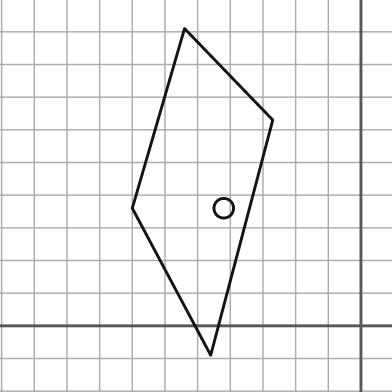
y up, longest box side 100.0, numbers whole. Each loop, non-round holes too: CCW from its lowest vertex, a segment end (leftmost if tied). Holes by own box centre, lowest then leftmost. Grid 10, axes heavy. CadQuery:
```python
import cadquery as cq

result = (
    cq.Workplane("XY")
    .moveTo(-46.0, -9.0)
    .lineTo(-27.0, 63.0)
    .lineTo(-54.0, 91.0)
    .lineTo(-70.0, 36.0)
    .close()
    .moveTo(-42.0, 36.0)
    .circle(3.0)
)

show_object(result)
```